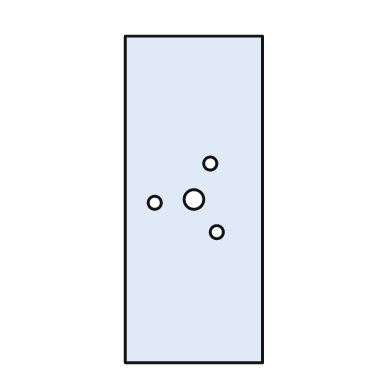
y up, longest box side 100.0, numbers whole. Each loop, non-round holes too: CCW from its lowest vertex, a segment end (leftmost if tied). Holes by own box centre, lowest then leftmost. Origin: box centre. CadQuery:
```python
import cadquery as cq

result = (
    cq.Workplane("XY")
    .moveTo(-21.0, -50.0)
    .lineTo(21.0, -50.0)
    .lineTo(21.0, 50.0)
    .lineTo(-21.0, 50.0)
    .close()
    .moveTo(7.0, -10.0)
    .circle(2.0)
    .moveTo(-12.0, -1.0)
    .circle(2.0)
    .moveTo(0.0, 0.0)
    .circle(3.0)
    .moveTo(5.0, 11.0)
    .circle(2.0)
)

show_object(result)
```